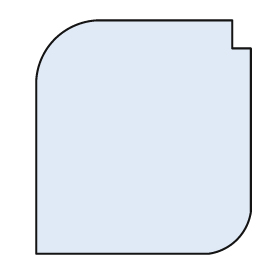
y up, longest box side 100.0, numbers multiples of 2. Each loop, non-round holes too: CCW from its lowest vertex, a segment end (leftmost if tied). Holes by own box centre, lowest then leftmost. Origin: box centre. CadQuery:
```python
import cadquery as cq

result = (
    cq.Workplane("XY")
    .moveTo(-46.0, -50.0)
    .lineTo(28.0, -50.0)
    .threePointArc((40.0, -44.0), (46.0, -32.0))
    .lineTo(46.0, 38.0)
    .lineTo(38.0, 38.0)
    .lineTo(38.0, 50.0)
    .lineTo(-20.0, 50.0)
    .threePointArc((-38.0, 42.0), (-46.0, 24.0))
    .close()
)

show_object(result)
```